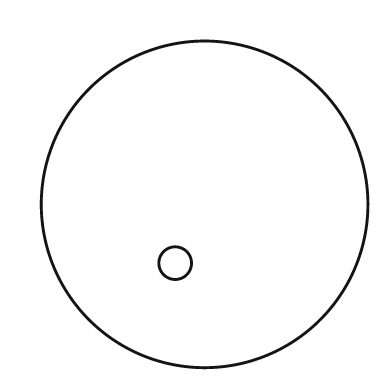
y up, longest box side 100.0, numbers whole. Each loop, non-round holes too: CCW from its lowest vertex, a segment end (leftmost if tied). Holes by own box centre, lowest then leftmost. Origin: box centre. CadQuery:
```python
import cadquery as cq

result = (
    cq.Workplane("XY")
    .moveTo(0.0, 0.0)
    .circle(50.0)
    .moveTo(-9.0, -18.0)
    .circle(5.0)
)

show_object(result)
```